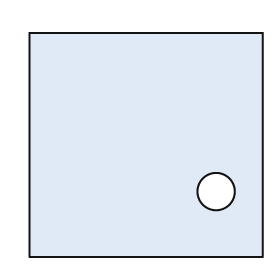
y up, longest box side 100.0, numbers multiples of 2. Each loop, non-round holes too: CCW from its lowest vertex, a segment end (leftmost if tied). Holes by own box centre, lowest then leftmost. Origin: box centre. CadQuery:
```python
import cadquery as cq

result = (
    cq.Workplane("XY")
    .moveTo(-50.0, -48.0)
    .lineTo(50.0, -48.0)
    .lineTo(50.0, 48.0)
    .lineTo(-50.0, 48.0)
    .close()
    .moveTo(30.0, -20.0)
    .circle(8.0)
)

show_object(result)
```